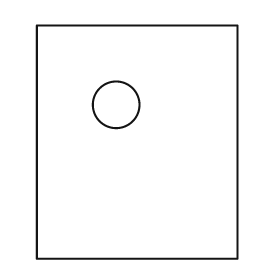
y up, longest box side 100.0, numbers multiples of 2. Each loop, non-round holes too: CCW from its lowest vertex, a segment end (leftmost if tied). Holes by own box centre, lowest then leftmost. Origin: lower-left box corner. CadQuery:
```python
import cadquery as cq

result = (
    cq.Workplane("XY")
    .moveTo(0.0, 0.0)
    .lineTo(86.0, 0.0)
    .lineTo(86.0, 100.0)
    .lineTo(0.0, 100.0)
    .close()
    .moveTo(34.0, 66.0)
    .circle(10.0)
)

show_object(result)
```